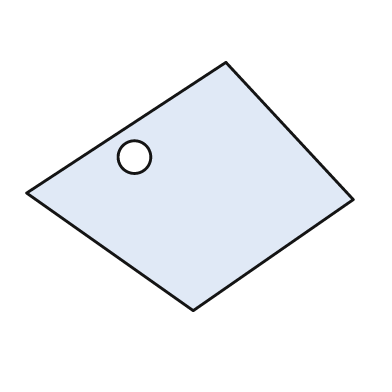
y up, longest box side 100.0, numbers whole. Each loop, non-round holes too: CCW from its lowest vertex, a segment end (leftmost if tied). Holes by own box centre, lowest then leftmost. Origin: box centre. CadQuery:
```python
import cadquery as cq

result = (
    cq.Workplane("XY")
    .moveTo(1.0, -38.0)
    .lineTo(50.0, -4.0)
    .lineTo(11.0, 38.0)
    .lineTo(-50.0, -2.0)
    .close()
    .moveTo(-17.0, 9.0)
    .circle(5.0)
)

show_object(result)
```